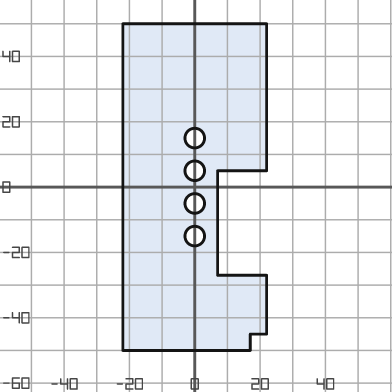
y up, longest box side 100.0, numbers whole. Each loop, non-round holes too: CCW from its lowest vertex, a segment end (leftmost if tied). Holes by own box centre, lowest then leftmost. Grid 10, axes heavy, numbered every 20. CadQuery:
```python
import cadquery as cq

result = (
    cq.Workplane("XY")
    .moveTo(-22.0, -50.0)
    .lineTo(17.0, -50.0)
    .lineTo(17.0, -45.0)
    .lineTo(22.0, -45.0)
    .lineTo(22.0, -27.0)
    .lineTo(7.0, -27.0)
    .lineTo(7.0, 5.0)
    .lineTo(22.0, 5.0)
    .lineTo(22.0, 50.0)
    .lineTo(-22.0, 50.0)
    .close()
    .moveTo(0.0, -15.0)
    .circle(3.0)
    .moveTo(0.0, -5.0)
    .circle(3.0)
    .moveTo(0.0, 5.0)
    .circle(3.0)
    .moveTo(0.0, 15.0)
    .circle(3.0)
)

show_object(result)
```